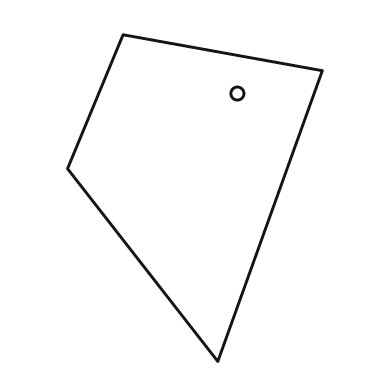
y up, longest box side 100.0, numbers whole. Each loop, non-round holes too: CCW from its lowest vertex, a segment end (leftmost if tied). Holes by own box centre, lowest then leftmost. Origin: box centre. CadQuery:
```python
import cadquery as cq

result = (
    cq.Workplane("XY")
    .moveTo(7.0, -50.0)
    .lineTo(39.0, 39.0)
    .lineTo(-22.0, 50.0)
    .lineTo(-39.0, 9.0)
    .close()
    .moveTo(13.0, 32.0)
    .circle(2.0)
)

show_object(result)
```